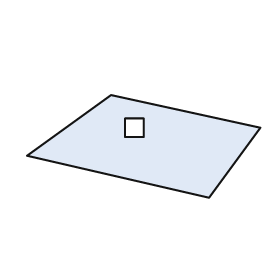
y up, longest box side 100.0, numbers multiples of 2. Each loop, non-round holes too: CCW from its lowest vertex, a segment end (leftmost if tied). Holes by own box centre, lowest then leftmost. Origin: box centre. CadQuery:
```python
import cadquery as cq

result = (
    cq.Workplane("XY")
    .moveTo(28.0, -22.0)
    .lineTo(50.0, 8.0)
    .lineTo(-14.0, 22.0)
    .lineTo(-50.0, -4.0)
    .close()
    .moveTo(-8.0, 4.0)
    .lineTo(0.0, 4.0)
    .lineTo(0.0, 12.0)
    .lineTo(-8.0, 12.0)
    .close()
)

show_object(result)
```